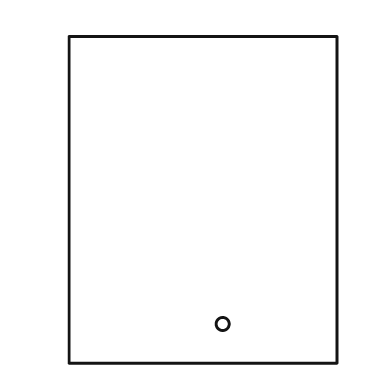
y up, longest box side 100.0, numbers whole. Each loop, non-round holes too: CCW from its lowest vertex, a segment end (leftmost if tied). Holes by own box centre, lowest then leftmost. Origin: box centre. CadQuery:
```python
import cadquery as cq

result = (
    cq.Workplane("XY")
    .moveTo(-41.0, -50.0)
    .lineTo(41.0, -50.0)
    .lineTo(41.0, 50.0)
    .lineTo(-41.0, 50.0)
    .close()
    .moveTo(6.0, -38.0)
    .circle(2.0)
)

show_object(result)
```